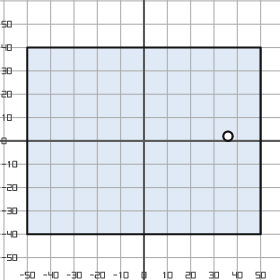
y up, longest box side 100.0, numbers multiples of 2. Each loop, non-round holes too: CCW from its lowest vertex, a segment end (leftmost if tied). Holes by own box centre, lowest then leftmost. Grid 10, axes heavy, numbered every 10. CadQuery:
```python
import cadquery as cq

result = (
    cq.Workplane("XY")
    .moveTo(-50.0, -40.0)
    .lineTo(50.0, -40.0)
    .lineTo(50.0, 40.0)
    .lineTo(-50.0, 40.0)
    .close()
    .moveTo(36.0, 2.0)
    .circle(2.0)
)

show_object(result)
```